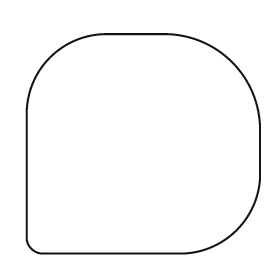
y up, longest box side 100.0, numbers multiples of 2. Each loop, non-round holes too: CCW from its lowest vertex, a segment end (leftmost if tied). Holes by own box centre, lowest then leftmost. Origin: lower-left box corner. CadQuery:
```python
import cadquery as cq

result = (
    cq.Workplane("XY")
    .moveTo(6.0, 0.0)
    .lineTo(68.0, 0.0)
    .threePointArc((90.0, 10.0), (100.0, 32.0))
    .lineTo(100.0, 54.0)
    .threePointArc((88.0, 82.0), (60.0, 94.0))
    .lineTo(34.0, 94.0)
    .threePointArc((10.0, 84.0), (0.0, 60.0))
    .lineTo(0.0, 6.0)
    .threePointArc((2.0, 2.0), (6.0, 0.0))
    .close()
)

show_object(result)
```